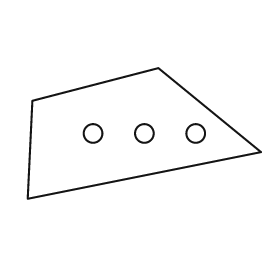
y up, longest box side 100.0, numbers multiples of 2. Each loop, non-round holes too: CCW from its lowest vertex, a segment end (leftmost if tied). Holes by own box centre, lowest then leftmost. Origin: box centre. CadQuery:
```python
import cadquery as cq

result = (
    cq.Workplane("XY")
    .moveTo(-50.0, -28.0)
    .lineTo(50.0, -8.0)
    .lineTo(6.0, 28.0)
    .lineTo(-48.0, 14.0)
    .close()
    .moveTo(-22.0, 0.0)
    .circle(4.0)
    .moveTo(0.0, 0.0)
    .circle(4.0)
    .moveTo(22.0, 0.0)
    .circle(4.0)
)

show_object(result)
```